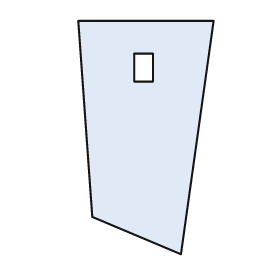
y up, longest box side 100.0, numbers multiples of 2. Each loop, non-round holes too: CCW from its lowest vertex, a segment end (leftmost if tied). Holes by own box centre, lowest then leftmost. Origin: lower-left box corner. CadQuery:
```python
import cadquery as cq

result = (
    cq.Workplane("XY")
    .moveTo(44.0, 0.0)
    .lineTo(58.0, 100.0)
    .lineTo(0.0, 100.0)
    .lineTo(6.0, 16.0)
    .close()
    .moveTo(24.0, 74.0)
    .lineTo(32.0, 74.0)
    .lineTo(32.0, 86.0)
    .lineTo(24.0, 86.0)
    .close()
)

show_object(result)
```